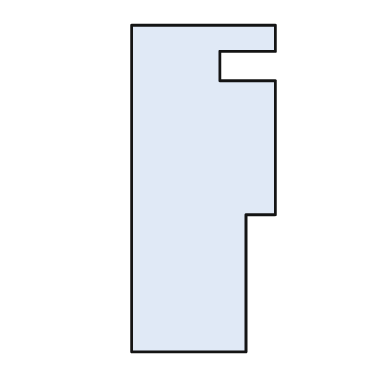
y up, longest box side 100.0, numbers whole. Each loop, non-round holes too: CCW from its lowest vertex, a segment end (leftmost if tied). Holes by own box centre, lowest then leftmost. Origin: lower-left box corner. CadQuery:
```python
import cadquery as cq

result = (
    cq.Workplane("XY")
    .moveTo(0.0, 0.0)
    .lineTo(35.0, 0.0)
    .lineTo(35.0, 42.0)
    .lineTo(44.0, 42.0)
    .lineTo(44.0, 83.0)
    .lineTo(27.0, 83.0)
    .lineTo(27.0, 92.0)
    .lineTo(44.0, 92.0)
    .lineTo(44.0, 100.0)
    .lineTo(0.0, 100.0)
    .close()
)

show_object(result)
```